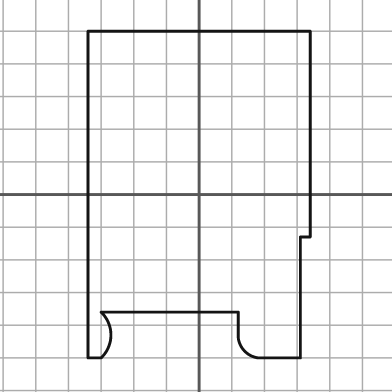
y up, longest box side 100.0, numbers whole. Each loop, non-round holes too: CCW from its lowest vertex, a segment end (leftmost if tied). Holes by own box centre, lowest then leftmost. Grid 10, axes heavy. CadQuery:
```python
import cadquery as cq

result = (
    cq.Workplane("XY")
    .moveTo(-34.0, -50.0)
    .lineTo(-30.0, -50.0)
    .threePointArc((-27.0, -43.0), (-30.0, -36.0))
    .lineTo(12.0, -36.0)
    .lineTo(12.0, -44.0)
    .threePointArc((14.0, -48.0), (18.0, -50.0))
    .lineTo(31.0, -50.0)
    .lineTo(31.0, -13.0)
    .lineTo(34.0, -13.0)
    .lineTo(34.0, 50.0)
    .lineTo(-34.0, 50.0)
    .close()
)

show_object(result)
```